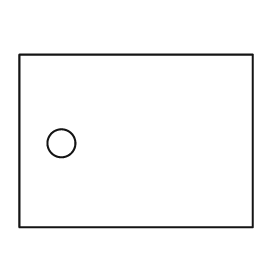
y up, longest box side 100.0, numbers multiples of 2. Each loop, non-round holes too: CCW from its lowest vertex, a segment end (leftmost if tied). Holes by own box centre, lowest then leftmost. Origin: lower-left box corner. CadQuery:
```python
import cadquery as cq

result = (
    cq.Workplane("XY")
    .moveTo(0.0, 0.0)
    .lineTo(100.0, 0.0)
    .lineTo(100.0, 74.0)
    .lineTo(0.0, 74.0)
    .close()
    .moveTo(18.0, 36.0)
    .circle(6.0)
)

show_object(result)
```